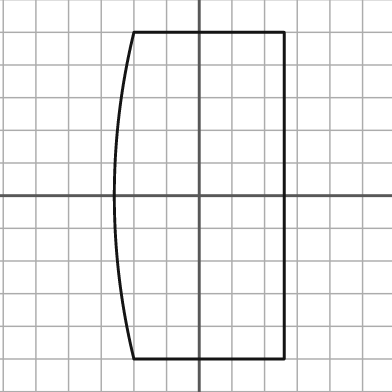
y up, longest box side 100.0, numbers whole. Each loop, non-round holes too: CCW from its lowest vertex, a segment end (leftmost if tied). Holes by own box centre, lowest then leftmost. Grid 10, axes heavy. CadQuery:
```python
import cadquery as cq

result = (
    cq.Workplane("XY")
    .moveTo(-20.0, -50.0)
    .lineTo(26.0, -50.0)
    .lineTo(26.0, 50.0)
    .lineTo(-20.0, 50.0)
    .threePointArc((-26.0, 0.0), (-20.0, -50.0))
    .close()
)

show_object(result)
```